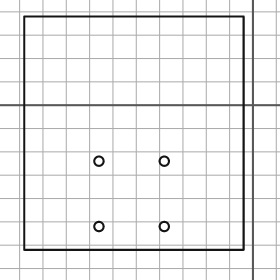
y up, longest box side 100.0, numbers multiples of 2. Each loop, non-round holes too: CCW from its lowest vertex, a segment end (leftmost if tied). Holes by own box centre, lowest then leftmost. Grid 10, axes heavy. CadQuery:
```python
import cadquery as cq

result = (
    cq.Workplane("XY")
    .moveTo(-98.0, -62.0)
    .lineTo(-4.0, -62.0)
    .lineTo(-4.0, 38.0)
    .lineTo(-98.0, 38.0)
    .close()
    .moveTo(-66.0, -52.0)
    .circle(2.0)
    .moveTo(-38.0, -52.0)
    .circle(2.0)
    .moveTo(-66.0, -24.0)
    .circle(2.0)
    .moveTo(-38.0, -24.0)
    .circle(2.0)
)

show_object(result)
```